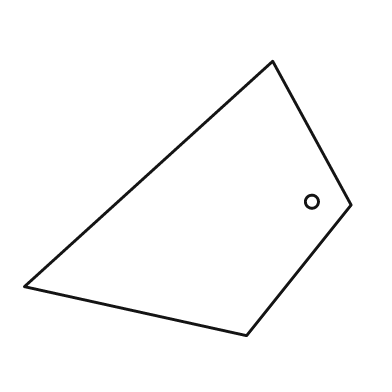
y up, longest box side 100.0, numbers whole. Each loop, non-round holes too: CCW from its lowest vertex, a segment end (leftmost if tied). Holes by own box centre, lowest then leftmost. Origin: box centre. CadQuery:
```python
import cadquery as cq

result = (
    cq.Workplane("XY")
    .moveTo(18.0, -42.0)
    .lineTo(50.0, -2.0)
    .lineTo(26.0, 42.0)
    .lineTo(-50.0, -27.0)
    .close()
    .moveTo(38.0, -1.0)
    .circle(2.0)
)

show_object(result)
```